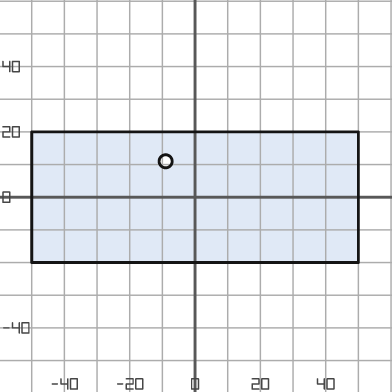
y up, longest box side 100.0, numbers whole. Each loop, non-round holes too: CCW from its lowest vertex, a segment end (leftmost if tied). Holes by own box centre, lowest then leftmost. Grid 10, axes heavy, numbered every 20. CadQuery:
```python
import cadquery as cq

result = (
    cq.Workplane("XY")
    .moveTo(-50.0, -20.0)
    .lineTo(50.0, -20.0)
    .lineTo(50.0, 20.0)
    .lineTo(-50.0, 20.0)
    .close()
    .moveTo(-9.0, 11.0)
    .circle(2.0)
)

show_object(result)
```